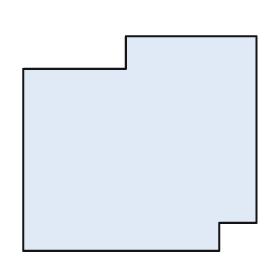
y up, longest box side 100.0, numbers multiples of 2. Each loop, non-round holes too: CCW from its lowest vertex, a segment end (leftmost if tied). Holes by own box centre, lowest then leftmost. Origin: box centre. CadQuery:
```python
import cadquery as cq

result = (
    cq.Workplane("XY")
    .moveTo(-50.0, -46.0)
    .lineTo(34.0, -46.0)
    .lineTo(34.0, -34.0)
    .lineTo(50.0, -34.0)
    .lineTo(50.0, 46.0)
    .lineTo(-6.0, 46.0)
    .lineTo(-6.0, 32.0)
    .lineTo(-50.0, 32.0)
    .close()
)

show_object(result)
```